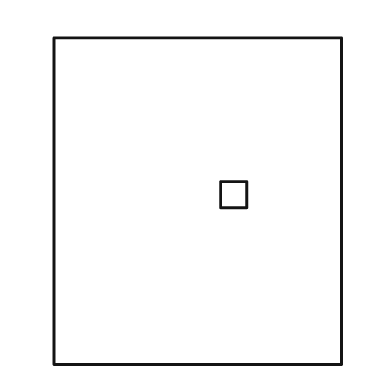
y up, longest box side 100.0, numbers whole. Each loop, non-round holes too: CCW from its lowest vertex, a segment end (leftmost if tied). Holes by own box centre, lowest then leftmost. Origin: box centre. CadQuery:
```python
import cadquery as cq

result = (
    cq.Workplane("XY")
    .moveTo(-44.0, -50.0)
    .lineTo(44.0, -50.0)
    .lineTo(44.0, 50.0)
    .lineTo(-44.0, 50.0)
    .close()
    .moveTo(7.0, -2.0)
    .lineTo(15.0, -2.0)
    .lineTo(15.0, 6.0)
    .lineTo(7.0, 6.0)
    .close()
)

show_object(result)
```